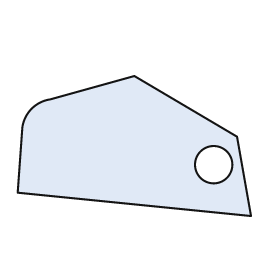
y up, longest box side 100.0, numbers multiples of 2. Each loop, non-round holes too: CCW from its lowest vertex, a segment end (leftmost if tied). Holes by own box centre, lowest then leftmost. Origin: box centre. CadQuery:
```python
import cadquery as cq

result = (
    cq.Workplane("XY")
    .moveTo(50.0, -30.0)
    .lineTo(44.0, 4.0)
    .lineTo(0.0, 30.0)
    .lineTo(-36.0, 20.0)
    .threePointArc((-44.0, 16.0), (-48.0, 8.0))
    .lineTo(-50.0, -20.0)
    .close()
    .moveTo(34.0, -8.0)
    .circle(8.0)
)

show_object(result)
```